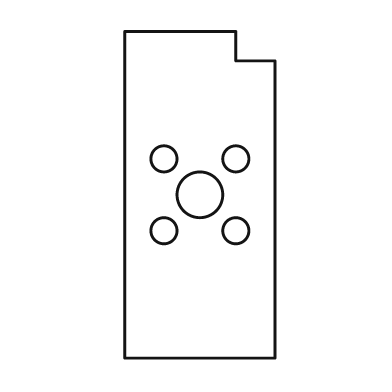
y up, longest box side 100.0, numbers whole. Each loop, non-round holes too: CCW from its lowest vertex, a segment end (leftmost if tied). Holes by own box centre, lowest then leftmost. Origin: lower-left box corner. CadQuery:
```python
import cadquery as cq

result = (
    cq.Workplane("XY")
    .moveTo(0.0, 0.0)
    .lineTo(46.0, 0.0)
    .lineTo(46.0, 91.0)
    .lineTo(34.0, 91.0)
    .lineTo(34.0, 100.0)
    .lineTo(0.0, 100.0)
    .close()
    .moveTo(12.0, 39.0)
    .circle(4.0)
    .moveTo(34.0, 39.0)
    .circle(4.0)
    .moveTo(23.0, 50.0)
    .circle(7.0)
    .moveTo(12.0, 61.0)
    .circle(4.0)
    .moveTo(34.0, 61.0)
    .circle(4.0)
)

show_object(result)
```